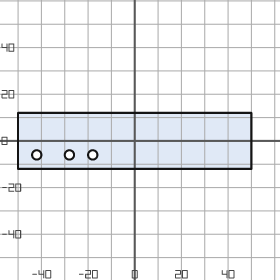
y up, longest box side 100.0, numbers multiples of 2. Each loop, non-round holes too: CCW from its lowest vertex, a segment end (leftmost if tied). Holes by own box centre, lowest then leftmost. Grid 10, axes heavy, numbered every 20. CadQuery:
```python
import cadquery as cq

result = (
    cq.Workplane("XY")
    .moveTo(-50.0, -12.0)
    .lineTo(50.0, -12.0)
    .lineTo(50.0, 12.0)
    .lineTo(-50.0, 12.0)
    .close()
    .moveTo(-42.0, -6.0)
    .circle(2.0)
    .moveTo(-28.0, -6.0)
    .circle(2.0)
    .moveTo(-18.0, -6.0)
    .circle(2.0)
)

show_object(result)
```